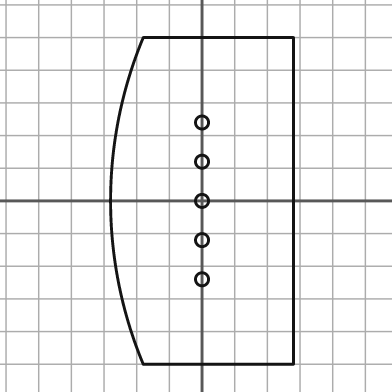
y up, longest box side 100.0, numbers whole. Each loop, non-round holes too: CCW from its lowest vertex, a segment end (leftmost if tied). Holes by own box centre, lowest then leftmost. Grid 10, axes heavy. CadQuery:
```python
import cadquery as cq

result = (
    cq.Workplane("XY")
    .moveTo(-18.0, -50.0)
    .lineTo(28.0, -50.0)
    .lineTo(28.0, 50.0)
    .lineTo(-18.0, 50.0)
    .threePointArc((-28.0, 0.0), (-18.0, -50.0))
    .close()
    .moveTo(0.0, -24.0)
    .circle(2.0)
    .moveTo(0.0, -12.0)
    .circle(2.0)
    .moveTo(0.0, 0.0)
    .circle(2.0)
    .moveTo(0.0, 12.0)
    .circle(2.0)
    .moveTo(0.0, 24.0)
    .circle(2.0)
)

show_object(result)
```